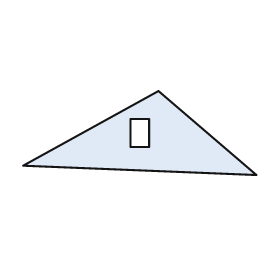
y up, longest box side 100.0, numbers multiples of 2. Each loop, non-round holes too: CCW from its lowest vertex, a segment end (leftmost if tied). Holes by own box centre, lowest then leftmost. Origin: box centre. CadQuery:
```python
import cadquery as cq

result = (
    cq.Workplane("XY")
    .moveTo(50.0, -18.0)
    .lineTo(8.0, 18.0)
    .lineTo(-50.0, -14.0)
    .close()
    .moveTo(-4.0, -6.0)
    .lineTo(4.0, -6.0)
    .lineTo(4.0, 6.0)
    .lineTo(-4.0, 6.0)
    .close()
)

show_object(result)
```